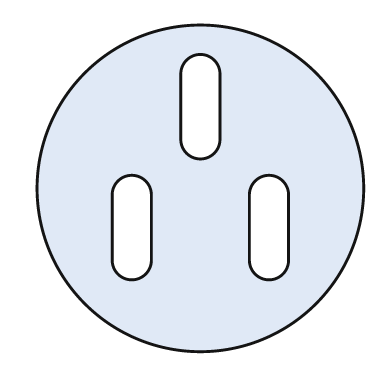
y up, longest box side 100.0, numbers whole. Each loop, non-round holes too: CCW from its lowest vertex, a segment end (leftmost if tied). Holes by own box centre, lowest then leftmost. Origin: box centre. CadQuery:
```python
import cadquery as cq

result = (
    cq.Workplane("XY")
    .moveTo(0.0, 0.0)
    .circle(50.0)
    .moveTo(-27.0, -22.0)
    .threePointArc((-21.0, -28.0), (-15.0, -22.0))
    .lineTo(-15.0, -2.0)
    .threePointArc((-21.0, 4.0), (-27.0, -2.0))
    .close()
    .moveTo(15.0, -22.0)
    .threePointArc((21.0, -28.0), (27.0, -22.0))
    .lineTo(27.0, -2.0)
    .threePointArc((21.0, 4.0), (15.0, -2.0))
    .close()
    .moveTo(-6.0, 15.0)
    .threePointArc((0.0, 9.0), (6.0, 15.0))
    .lineTo(6.0, 35.0)
    .threePointArc((0.0, 41.0), (-6.0, 35.0))
    .close()
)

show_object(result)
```